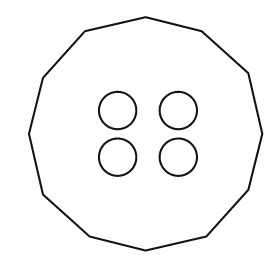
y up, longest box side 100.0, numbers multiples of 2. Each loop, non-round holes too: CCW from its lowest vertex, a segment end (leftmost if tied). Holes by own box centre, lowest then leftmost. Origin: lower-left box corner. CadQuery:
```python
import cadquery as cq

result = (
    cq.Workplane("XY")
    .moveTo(50.0, 0.0)
    .lineTo(76.0, 6.0)
    .lineTo(94.0, 26.0)
    .lineTo(100.0, 50.0)
    .lineTo(94.0, 76.0)
    .lineTo(74.0, 94.0)
    .lineTo(50.0, 100.0)
    .lineTo(24.0, 94.0)
    .lineTo(6.0, 74.0)
    .lineTo(0.0, 50.0)
    .lineTo(6.0, 24.0)
    .lineTo(26.0, 6.0)
    .close()
    .moveTo(38.0, 40.0)
    .circle(8.0)
    .moveTo(64.0, 40.0)
    .circle(8.0)
    .moveTo(38.0, 60.0)
    .circle(8.0)
    .moveTo(64.0, 60.0)
    .circle(8.0)
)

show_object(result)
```